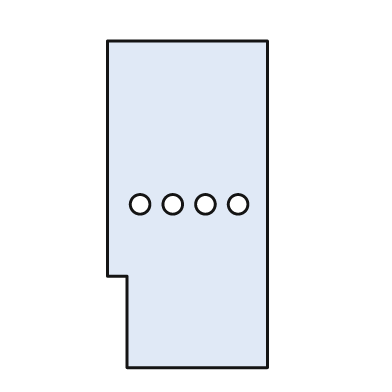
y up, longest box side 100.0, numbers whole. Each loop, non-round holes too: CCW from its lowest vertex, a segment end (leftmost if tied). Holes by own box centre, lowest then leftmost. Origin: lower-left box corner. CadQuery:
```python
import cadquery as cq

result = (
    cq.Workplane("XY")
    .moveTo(6.0, 0.0)
    .lineTo(49.0, 0.0)
    .lineTo(49.0, 100.0)
    .lineTo(0.0, 100.0)
    .lineTo(0.0, 28.0)
    .lineTo(6.0, 28.0)
    .close()
    .moveTo(10.0, 50.0)
    .circle(3.0)
    .moveTo(20.0, 50.0)
    .circle(3.0)
    .moveTo(30.0, 50.0)
    .circle(3.0)
    .moveTo(40.0, 50.0)
    .circle(3.0)
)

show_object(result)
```